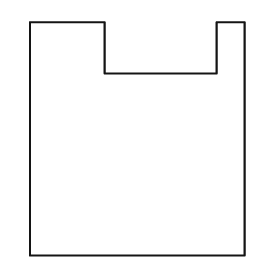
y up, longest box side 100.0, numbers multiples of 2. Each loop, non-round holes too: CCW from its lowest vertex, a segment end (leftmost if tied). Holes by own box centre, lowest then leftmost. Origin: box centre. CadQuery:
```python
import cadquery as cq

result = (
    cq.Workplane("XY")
    .moveTo(-46.0, -50.0)
    .lineTo(46.0, -50.0)
    .lineTo(46.0, 50.0)
    .lineTo(34.0, 50.0)
    .lineTo(34.0, 28.0)
    .lineTo(-14.0, 28.0)
    .lineTo(-14.0, 50.0)
    .lineTo(-46.0, 50.0)
    .close()
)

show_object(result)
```